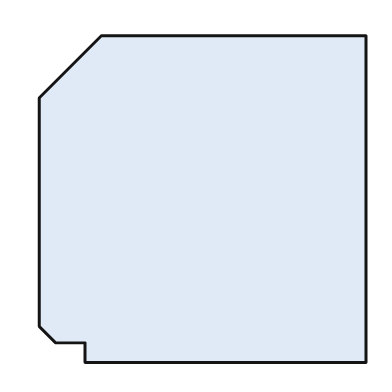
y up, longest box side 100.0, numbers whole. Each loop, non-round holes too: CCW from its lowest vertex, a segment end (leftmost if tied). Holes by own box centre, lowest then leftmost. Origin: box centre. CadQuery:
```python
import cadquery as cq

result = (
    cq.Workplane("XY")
    .moveTo(-36.0, -50.0)
    .lineTo(50.0, -50.0)
    .lineTo(50.0, 50.0)
    .lineTo(-31.0, 50.0)
    .lineTo(-50.0, 31.0)
    .lineTo(-50.0, -39.0)
    .lineTo(-45.0, -44.0)
    .lineTo(-36.0, -44.0)
    .close()
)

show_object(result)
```